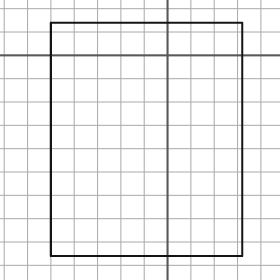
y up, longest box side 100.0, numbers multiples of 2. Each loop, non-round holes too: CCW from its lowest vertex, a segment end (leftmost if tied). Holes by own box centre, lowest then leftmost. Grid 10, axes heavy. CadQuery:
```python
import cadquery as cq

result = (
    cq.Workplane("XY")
    .moveTo(-50.0, -86.0)
    .lineTo(32.0, -86.0)
    .lineTo(32.0, 14.0)
    .lineTo(-50.0, 14.0)
    .close()
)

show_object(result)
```